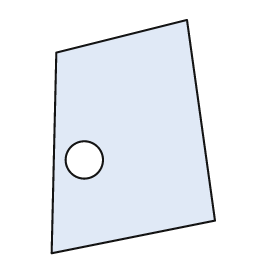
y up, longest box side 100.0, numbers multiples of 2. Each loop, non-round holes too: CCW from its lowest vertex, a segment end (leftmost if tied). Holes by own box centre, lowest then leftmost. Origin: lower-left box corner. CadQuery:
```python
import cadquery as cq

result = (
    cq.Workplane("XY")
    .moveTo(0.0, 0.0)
    .lineTo(70.0, 14.0)
    .lineTo(58.0, 100.0)
    .lineTo(2.0, 86.0)
    .close()
    .moveTo(14.0, 40.0)
    .circle(8.0)
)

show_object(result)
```